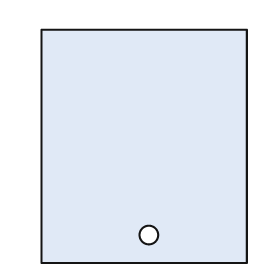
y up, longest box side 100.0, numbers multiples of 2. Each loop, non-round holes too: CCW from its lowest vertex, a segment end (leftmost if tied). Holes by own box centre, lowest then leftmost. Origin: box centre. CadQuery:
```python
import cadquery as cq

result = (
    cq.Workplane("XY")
    .moveTo(-44.0, -50.0)
    .lineTo(44.0, -50.0)
    .lineTo(44.0, 50.0)
    .lineTo(-44.0, 50.0)
    .close()
    .moveTo(2.0, -38.0)
    .circle(4.0)
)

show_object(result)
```